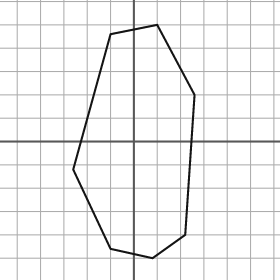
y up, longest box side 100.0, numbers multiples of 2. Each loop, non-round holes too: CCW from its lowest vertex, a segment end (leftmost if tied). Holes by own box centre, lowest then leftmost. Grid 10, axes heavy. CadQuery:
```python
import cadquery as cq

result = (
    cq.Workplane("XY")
    .moveTo(8.0, -50.0)
    .lineTo(22.0, -40.0)
    .lineTo(26.0, 20.0)
    .lineTo(10.0, 50.0)
    .lineTo(-10.0, 46.0)
    .lineTo(-26.0, -12.0)
    .lineTo(-10.0, -46.0)
    .close()
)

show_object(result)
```